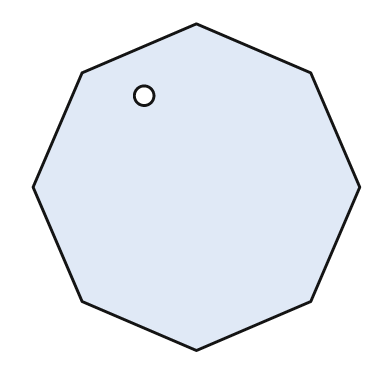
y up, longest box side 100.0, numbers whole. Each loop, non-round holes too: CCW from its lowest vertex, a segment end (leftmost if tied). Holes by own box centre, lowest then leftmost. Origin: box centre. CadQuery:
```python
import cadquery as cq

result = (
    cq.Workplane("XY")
    .moveTo(0.0, -50.0)
    .lineTo(35.0, -35.0)
    .lineTo(50.0, 0.0)
    .lineTo(35.0, 35.0)
    .lineTo(0.0, 50.0)
    .lineTo(-35.0, 35.0)
    .lineTo(-50.0, 0.0)
    .lineTo(-35.0, -35.0)
    .close()
    .moveTo(-16.0, 28.0)
    .circle(3.0)
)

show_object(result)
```